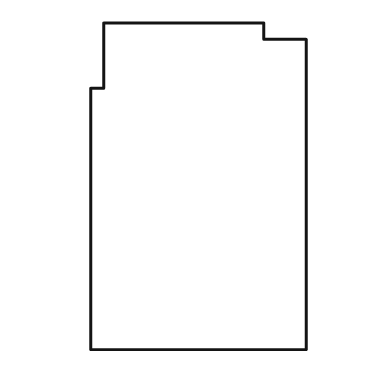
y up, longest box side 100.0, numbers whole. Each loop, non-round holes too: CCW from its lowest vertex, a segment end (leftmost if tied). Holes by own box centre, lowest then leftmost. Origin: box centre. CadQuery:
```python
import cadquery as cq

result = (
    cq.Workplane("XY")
    .moveTo(-33.0, -50.0)
    .lineTo(33.0, -50.0)
    .lineTo(33.0, 45.0)
    .lineTo(20.0, 45.0)
    .lineTo(20.0, 50.0)
    .lineTo(-29.0, 50.0)
    .lineTo(-29.0, 30.0)
    .lineTo(-33.0, 30.0)
    .close()
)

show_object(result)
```